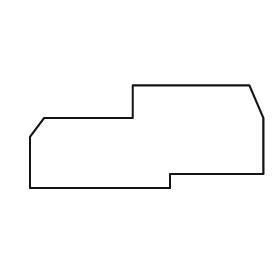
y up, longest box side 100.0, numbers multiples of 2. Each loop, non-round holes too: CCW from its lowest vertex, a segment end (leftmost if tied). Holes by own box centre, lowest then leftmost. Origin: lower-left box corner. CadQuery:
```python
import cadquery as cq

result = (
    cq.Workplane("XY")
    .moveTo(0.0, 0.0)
    .lineTo(60.0, 0.0)
    .lineTo(60.0, 6.0)
    .lineTo(100.0, 6.0)
    .lineTo(100.0, 30.0)
    .lineTo(94.0, 44.0)
    .lineTo(44.0, 44.0)
    .lineTo(44.0, 30.0)
    .lineTo(6.0, 30.0)
    .lineTo(0.0, 22.0)
    .close()
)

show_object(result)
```